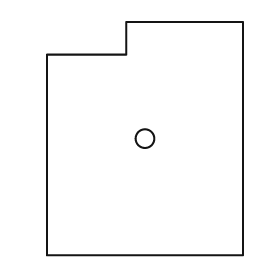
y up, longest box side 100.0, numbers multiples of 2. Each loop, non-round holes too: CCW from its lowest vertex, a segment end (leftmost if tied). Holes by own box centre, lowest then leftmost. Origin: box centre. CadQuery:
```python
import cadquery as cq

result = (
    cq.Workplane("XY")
    .moveTo(-42.0, -50.0)
    .lineTo(42.0, -50.0)
    .lineTo(42.0, 50.0)
    .lineTo(-8.0, 50.0)
    .lineTo(-8.0, 36.0)
    .lineTo(-42.0, 36.0)
    .close()
    .moveTo(0.0, 0.0)
    .circle(4.0)
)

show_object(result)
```